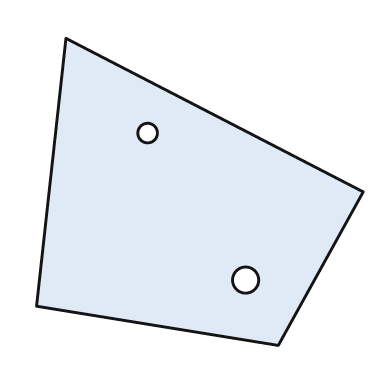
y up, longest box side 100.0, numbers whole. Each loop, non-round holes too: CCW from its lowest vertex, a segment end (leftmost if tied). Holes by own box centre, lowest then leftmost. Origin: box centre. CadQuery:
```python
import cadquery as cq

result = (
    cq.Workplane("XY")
    .moveTo(24.0, -47.0)
    .lineTo(50.0, 0.0)
    .lineTo(-41.0, 47.0)
    .lineTo(-50.0, -35.0)
    .close()
    .moveTo(14.0, -27.0)
    .circle(4.0)
    .moveTo(-16.0, 18.0)
    .circle(3.0)
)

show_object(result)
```